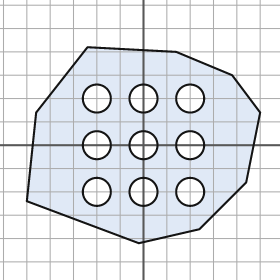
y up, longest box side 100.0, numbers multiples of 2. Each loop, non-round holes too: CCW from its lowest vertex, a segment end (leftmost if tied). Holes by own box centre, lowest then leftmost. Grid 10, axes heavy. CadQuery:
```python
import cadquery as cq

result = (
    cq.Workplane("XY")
    .moveTo(-2.0, -42.0)
    .lineTo(24.0, -36.0)
    .lineTo(44.0, -16.0)
    .lineTo(50.0, 14.0)
    .lineTo(38.0, 30.0)
    .lineTo(14.0, 40.0)
    .lineTo(-24.0, 42.0)
    .lineTo(-46.0, 14.0)
    .lineTo(-50.0, -24.0)
    .close()
    .moveTo(-20.0, -20.0)
    .circle(6.0)
    .moveTo(0.0, -20.0)
    .circle(6.0)
    .moveTo(20.0, -20.0)
    .circle(6.0)
    .moveTo(-20.0, 0.0)
    .circle(6.0)
    .moveTo(0.0, 0.0)
    .circle(6.0)
    .moveTo(20.0, 0.0)
    .circle(6.0)
    .moveTo(-20.0, 20.0)
    .circle(6.0)
    .moveTo(0.0, 20.0)
    .circle(6.0)
    .moveTo(20.0, 20.0)
    .circle(6.0)
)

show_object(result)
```